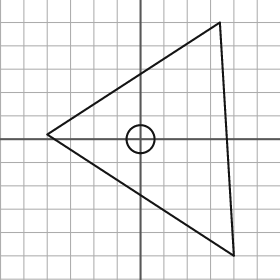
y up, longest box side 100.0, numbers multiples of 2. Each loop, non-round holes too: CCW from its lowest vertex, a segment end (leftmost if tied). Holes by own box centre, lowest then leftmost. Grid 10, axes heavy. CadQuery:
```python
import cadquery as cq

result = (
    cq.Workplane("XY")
    .moveTo(40.0, -50.0)
    .lineTo(34.0, 50.0)
    .lineTo(-40.0, 2.0)
    .close()
    .moveTo(0.0, 0.0)
    .circle(6.0)
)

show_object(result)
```